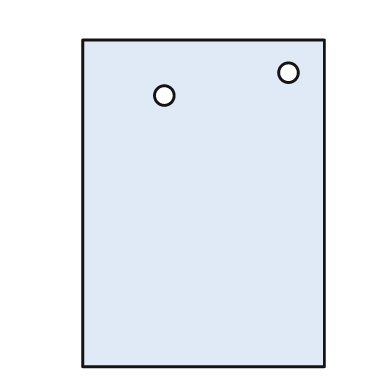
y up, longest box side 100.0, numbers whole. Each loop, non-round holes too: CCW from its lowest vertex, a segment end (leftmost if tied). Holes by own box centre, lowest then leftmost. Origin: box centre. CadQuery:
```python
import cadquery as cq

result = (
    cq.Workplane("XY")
    .moveTo(-37.0, -50.0)
    .lineTo(37.0, -50.0)
    .lineTo(37.0, 50.0)
    .lineTo(-37.0, 50.0)
    .close()
    .moveTo(-12.0, 33.0)
    .circle(3.0)
    .moveTo(26.0, 40.0)
    .circle(3.0)
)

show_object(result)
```